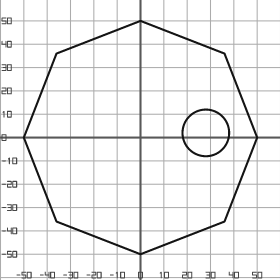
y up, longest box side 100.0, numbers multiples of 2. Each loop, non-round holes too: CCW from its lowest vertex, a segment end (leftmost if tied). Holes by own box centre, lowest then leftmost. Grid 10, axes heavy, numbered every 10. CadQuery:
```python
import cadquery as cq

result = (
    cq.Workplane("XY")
    .moveTo(0.0, -50.0)
    .lineTo(36.0, -36.0)
    .lineTo(50.0, 0.0)
    .lineTo(36.0, 36.0)
    .lineTo(0.0, 50.0)
    .lineTo(-36.0, 36.0)
    .lineTo(-50.0, 0.0)
    .lineTo(-36.0, -36.0)
    .close()
    .moveTo(28.0, 2.0)
    .circle(10.0)
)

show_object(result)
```